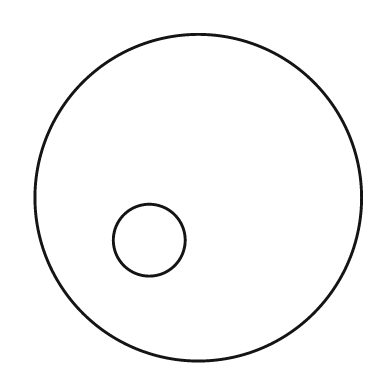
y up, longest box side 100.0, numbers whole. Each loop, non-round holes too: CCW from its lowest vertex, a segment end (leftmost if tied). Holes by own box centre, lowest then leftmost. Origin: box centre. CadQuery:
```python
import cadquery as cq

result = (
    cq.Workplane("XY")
    .moveTo(0.0, 0.0)
    .circle(50.0)
    .moveTo(-15.0, -13.0)
    .circle(11.0)
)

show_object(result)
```